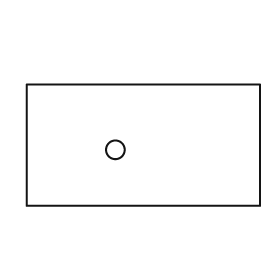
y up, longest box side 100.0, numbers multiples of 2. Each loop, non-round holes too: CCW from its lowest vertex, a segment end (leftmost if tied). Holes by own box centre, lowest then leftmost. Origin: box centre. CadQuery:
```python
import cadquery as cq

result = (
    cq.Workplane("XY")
    .moveTo(-50.0, -26.0)
    .lineTo(50.0, -26.0)
    .lineTo(50.0, 26.0)
    .lineTo(-50.0, 26.0)
    .close()
    .moveTo(-12.0, -2.0)
    .circle(4.0)
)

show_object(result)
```